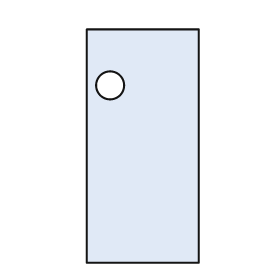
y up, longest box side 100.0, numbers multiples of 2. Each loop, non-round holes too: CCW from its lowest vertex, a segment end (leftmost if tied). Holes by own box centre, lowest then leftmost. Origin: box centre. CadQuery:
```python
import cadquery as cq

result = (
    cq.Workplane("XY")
    .moveTo(-24.0, -50.0)
    .lineTo(24.0, -50.0)
    .lineTo(24.0, 50.0)
    .lineTo(-24.0, 50.0)
    .close()
    .moveTo(-14.0, 26.0)
    .circle(6.0)
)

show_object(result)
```